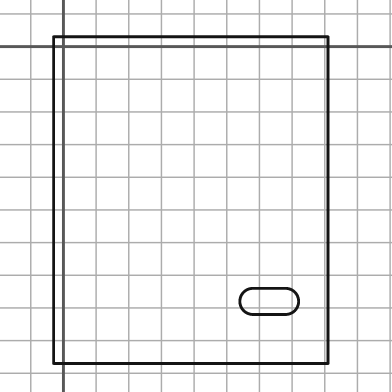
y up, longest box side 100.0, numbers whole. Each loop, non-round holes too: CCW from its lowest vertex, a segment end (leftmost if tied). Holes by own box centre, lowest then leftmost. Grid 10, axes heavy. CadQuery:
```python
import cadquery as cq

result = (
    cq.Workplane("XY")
    .moveTo(-3.0, -97.0)
    .lineTo(81.0, -97.0)
    .lineTo(81.0, 3.0)
    .lineTo(-3.0, 3.0)
    .close()
    .moveTo(58.0, -82.0)
    .lineTo(68.0, -82.0)
    .threePointArc((72.0, -78.0), (68.0, -74.0))
    .lineTo(58.0, -74.0)
    .threePointArc((54.0, -78.0), (58.0, -82.0))
    .close()
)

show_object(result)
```